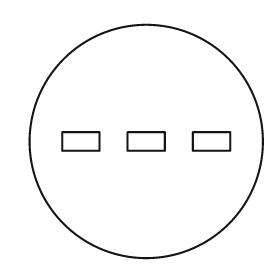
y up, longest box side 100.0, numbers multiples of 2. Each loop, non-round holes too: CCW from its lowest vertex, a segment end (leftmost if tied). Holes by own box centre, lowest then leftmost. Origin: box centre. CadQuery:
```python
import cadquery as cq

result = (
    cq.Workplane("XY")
    .moveTo(0.0, 0.0)
    .circle(50.0)
    .moveTo(-36.0, -4.0)
    .lineTo(-20.0, -4.0)
    .lineTo(-20.0, 4.0)
    .lineTo(-36.0, 4.0)
    .close()
    .moveTo(-8.0, -4.0)
    .lineTo(8.0, -4.0)
    .lineTo(8.0, 4.0)
    .lineTo(-8.0, 4.0)
    .close()
    .moveTo(20.0, -4.0)
    .lineTo(36.0, -4.0)
    .lineTo(36.0, 4.0)
    .lineTo(20.0, 4.0)
    .close()
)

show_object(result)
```